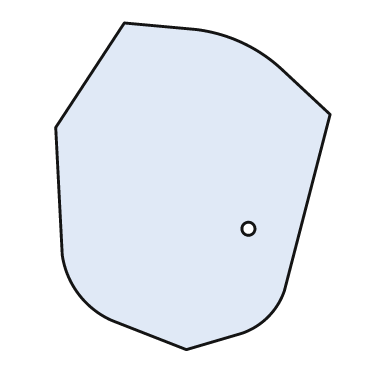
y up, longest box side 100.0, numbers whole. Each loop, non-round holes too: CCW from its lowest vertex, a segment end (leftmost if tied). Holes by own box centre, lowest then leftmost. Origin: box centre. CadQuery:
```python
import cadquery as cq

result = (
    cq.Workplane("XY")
    .moveTo(-2.0, -50.0)
    .lineTo(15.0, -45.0)
    .threePointArc((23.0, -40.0), (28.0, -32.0))
    .lineTo(42.0, 22.0)
    .lineTo(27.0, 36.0)
    .threePointArc((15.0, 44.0), (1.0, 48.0))
    .lineTo(-21.0, 50.0)
    .lineTo(-42.0, 18.0)
    .lineTo(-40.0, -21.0)
    .threePointArc((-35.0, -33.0), (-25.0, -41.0))
    .close()
    .moveTo(17.0, -13.0)
    .circle(2.0)
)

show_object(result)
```